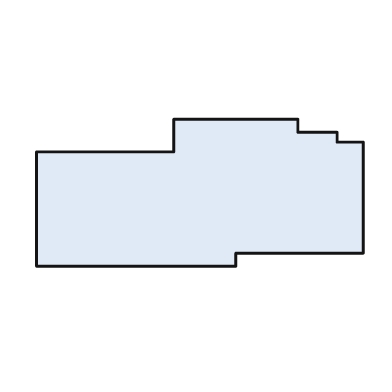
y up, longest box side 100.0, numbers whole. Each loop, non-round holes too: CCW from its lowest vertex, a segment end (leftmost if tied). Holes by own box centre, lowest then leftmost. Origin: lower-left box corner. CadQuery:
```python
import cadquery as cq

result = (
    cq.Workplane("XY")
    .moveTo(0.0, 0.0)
    .lineTo(61.0, 0.0)
    .lineTo(61.0, 4.0)
    .lineTo(100.0, 4.0)
    .lineTo(100.0, 38.0)
    .lineTo(92.0, 38.0)
    .lineTo(92.0, 41.0)
    .lineTo(80.0, 41.0)
    .lineTo(80.0, 45.0)
    .lineTo(42.0, 45.0)
    .lineTo(42.0, 35.0)
    .lineTo(0.0, 35.0)
    .close()
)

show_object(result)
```